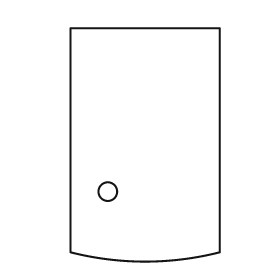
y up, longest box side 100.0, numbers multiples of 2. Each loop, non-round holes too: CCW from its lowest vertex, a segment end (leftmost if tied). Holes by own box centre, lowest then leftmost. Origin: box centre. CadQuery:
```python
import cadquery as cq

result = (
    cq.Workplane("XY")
    .moveTo(-32.0, -46.0)
    .threePointArc((0.0, -50.0), (32.0, -46.0))
    .lineTo(32.0, 50.0)
    .lineTo(-32.0, 50.0)
    .close()
    .moveTo(-16.0, -20.0)
    .circle(4.0)
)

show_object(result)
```